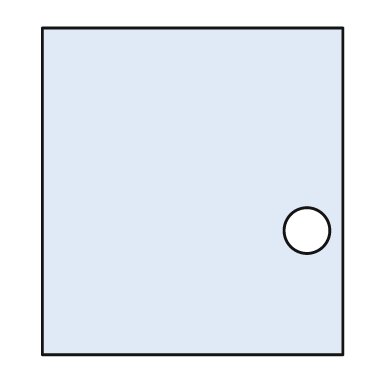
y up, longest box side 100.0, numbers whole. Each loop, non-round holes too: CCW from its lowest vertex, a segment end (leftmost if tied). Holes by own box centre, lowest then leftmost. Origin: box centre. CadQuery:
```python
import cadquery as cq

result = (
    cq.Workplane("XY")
    .moveTo(-46.0, -50.0)
    .lineTo(46.0, -50.0)
    .lineTo(46.0, 50.0)
    .lineTo(-46.0, 50.0)
    .close()
    .moveTo(35.0, -12.0)
    .circle(7.0)
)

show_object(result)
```